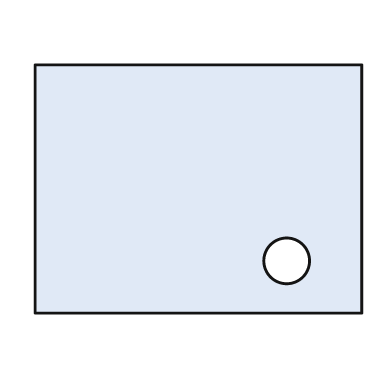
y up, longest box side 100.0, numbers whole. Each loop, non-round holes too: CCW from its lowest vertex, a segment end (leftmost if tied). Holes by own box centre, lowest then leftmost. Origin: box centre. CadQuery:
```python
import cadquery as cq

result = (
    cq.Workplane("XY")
    .moveTo(-50.0, -38.0)
    .lineTo(50.0, -38.0)
    .lineTo(50.0, 38.0)
    .lineTo(-50.0, 38.0)
    .close()
    .moveTo(27.0, -22.0)
    .circle(7.0)
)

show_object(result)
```